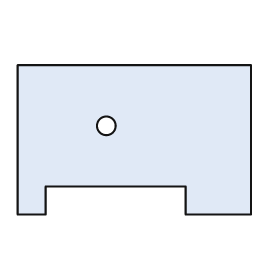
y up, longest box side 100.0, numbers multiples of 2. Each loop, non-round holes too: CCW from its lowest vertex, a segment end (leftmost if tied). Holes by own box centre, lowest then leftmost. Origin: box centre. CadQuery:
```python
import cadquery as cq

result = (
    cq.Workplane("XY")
    .moveTo(-50.0, -32.0)
    .lineTo(-38.0, -32.0)
    .lineTo(-38.0, -20.0)
    .lineTo(22.0, -20.0)
    .lineTo(22.0, -32.0)
    .lineTo(50.0, -32.0)
    .lineTo(50.0, 32.0)
    .lineTo(-50.0, 32.0)
    .close()
    .moveTo(-12.0, 6.0)
    .circle(4.0)
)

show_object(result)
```